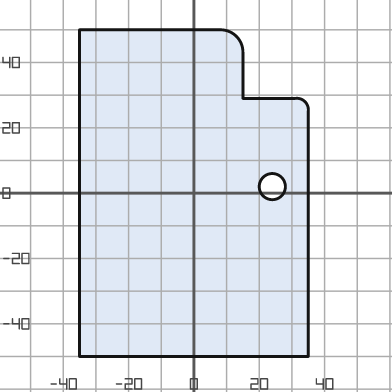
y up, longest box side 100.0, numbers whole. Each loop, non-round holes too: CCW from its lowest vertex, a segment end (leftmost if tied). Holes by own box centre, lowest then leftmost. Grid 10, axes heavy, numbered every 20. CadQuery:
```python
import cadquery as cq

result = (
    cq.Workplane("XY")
    .moveTo(-35.0, -50.0)
    .lineTo(35.0, -50.0)
    .lineTo(35.0, 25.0)
    .threePointArc((34.0, 28.0), (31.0, 29.0))
    .lineTo(15.0, 29.0)
    .lineTo(15.0, 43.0)
    .threePointArc((13.0, 48.0), (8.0, 50.0))
    .lineTo(-35.0, 50.0)
    .close()
    .moveTo(24.0, 2.0)
    .circle(4.0)
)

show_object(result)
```